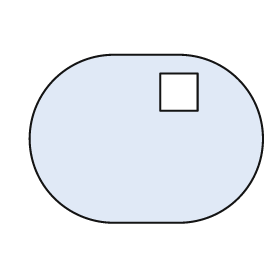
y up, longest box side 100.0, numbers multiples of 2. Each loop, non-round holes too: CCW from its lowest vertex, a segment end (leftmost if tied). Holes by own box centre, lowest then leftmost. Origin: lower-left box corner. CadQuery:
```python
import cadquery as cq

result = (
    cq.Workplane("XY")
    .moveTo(36.0, 0.0)
    .lineTo(64.0, 0.0)
    .threePointArc((100.0, 36.0), (64.0, 72.0))
    .lineTo(36.0, 72.0)
    .threePointArc((0.0, 36.0), (36.0, 0.0))
    .close()
    .moveTo(56.0, 48.0)
    .lineTo(72.0, 48.0)
    .lineTo(72.0, 64.0)
    .lineTo(56.0, 64.0)
    .close()
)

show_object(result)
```